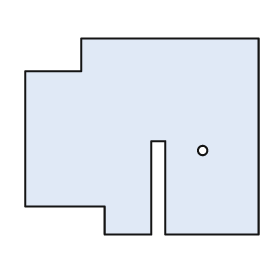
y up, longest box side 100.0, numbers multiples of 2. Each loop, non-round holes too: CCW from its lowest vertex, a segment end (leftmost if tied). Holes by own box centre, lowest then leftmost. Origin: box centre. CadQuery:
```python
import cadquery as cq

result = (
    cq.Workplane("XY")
    .moveTo(-16.0, -42.0)
    .lineTo(4.0, -42.0)
    .lineTo(4.0, -2.0)
    .lineTo(10.0, -2.0)
    .lineTo(10.0, -42.0)
    .lineTo(50.0, -42.0)
    .lineTo(50.0, 42.0)
    .lineTo(-26.0, 42.0)
    .lineTo(-26.0, 28.0)
    .lineTo(-50.0, 28.0)
    .lineTo(-50.0, -30.0)
    .lineTo(-16.0, -30.0)
    .close()
    .moveTo(26.0, -6.0)
    .circle(2.0)
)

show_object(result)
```